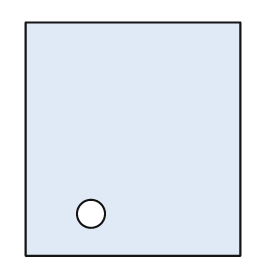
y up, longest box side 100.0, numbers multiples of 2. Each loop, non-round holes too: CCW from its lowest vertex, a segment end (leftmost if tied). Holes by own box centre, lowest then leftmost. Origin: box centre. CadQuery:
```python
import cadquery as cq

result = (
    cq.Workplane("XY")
    .moveTo(-46.0, -50.0)
    .lineTo(46.0, -50.0)
    .lineTo(46.0, 50.0)
    .lineTo(-46.0, 50.0)
    .close()
    .moveTo(-18.0, -32.0)
    .circle(6.0)
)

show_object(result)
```